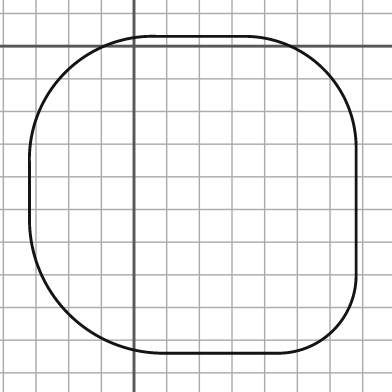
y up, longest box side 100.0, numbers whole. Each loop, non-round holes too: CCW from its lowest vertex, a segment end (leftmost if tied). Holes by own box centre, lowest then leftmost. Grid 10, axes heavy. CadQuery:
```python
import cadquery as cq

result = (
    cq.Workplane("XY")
    .moveTo(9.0, -94.0)
    .lineTo(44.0, -94.0)
    .threePointArc((61.0, -87.0), (68.0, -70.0))
    .lineTo(68.0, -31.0)
    .threePointArc((58.0, -7.0), (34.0, 3.0))
    .lineTo(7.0, 3.0)
    .threePointArc((-21.0, -8.0), (-32.0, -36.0))
    .lineTo(-32.0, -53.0)
    .threePointArc((-20.0, -82.0), (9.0, -94.0))
    .close()
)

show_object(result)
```